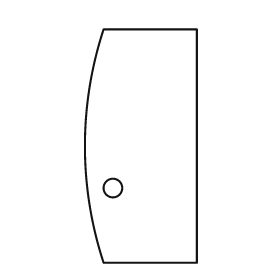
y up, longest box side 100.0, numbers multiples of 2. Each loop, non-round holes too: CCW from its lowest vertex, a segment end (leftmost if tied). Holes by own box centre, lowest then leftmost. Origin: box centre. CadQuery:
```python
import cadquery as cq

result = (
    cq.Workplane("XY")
    .moveTo(-16.0, -50.0)
    .lineTo(24.0, -50.0)
    .lineTo(24.0, 50.0)
    .lineTo(-16.0, 50.0)
    .threePointArc((-24.0, 0.0), (-16.0, -50.0))
    .close()
    .moveTo(-12.0, -18.0)
    .circle(4.0)
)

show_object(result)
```